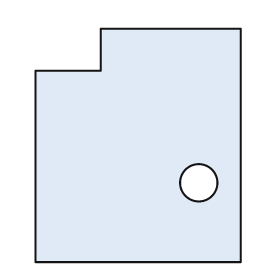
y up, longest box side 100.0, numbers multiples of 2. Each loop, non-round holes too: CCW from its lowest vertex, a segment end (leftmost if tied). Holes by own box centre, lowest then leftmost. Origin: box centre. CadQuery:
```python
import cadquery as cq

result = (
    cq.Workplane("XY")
    .moveTo(-44.0, -50.0)
    .lineTo(44.0, -50.0)
    .lineTo(44.0, 50.0)
    .lineTo(-16.0, 50.0)
    .lineTo(-16.0, 32.0)
    .lineTo(-44.0, 32.0)
    .close()
    .moveTo(26.0, -16.0)
    .circle(8.0)
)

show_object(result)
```